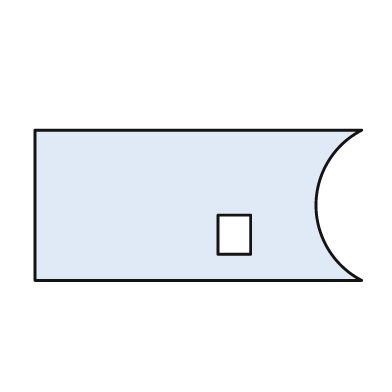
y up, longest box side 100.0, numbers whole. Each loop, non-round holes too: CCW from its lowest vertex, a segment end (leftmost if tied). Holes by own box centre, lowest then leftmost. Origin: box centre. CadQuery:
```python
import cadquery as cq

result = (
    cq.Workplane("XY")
    .moveTo(-50.0, -23.0)
    .lineTo(50.0, -23.0)
    .threePointArc((36.0, 0.0), (50.0, 23.0))
    .lineTo(-50.0, 23.0)
    .close()
    .moveTo(6.0, -15.0)
    .lineTo(16.0, -15.0)
    .lineTo(16.0, -3.0)
    .lineTo(6.0, -3.0)
    .close()
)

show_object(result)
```